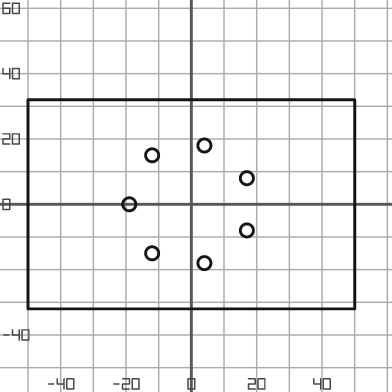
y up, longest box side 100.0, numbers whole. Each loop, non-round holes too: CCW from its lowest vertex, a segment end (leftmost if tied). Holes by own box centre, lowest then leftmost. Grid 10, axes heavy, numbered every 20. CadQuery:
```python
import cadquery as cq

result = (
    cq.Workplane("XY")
    .moveTo(-50.0, -32.0)
    .lineTo(50.0, -32.0)
    .lineTo(50.0, 32.0)
    .lineTo(-50.0, 32.0)
    .close()
    .moveTo(4.0, -18.0)
    .circle(2.0)
    .moveTo(-12.0, -15.0)
    .circle(2.0)
    .moveTo(17.0, -8.0)
    .circle(2.0)
    .moveTo(-19.0, 0.0)
    .circle(2.0)
    .moveTo(17.0, 8.0)
    .circle(2.0)
    .moveTo(-12.0, 15.0)
    .circle(2.0)
    .moveTo(4.0, 18.0)
    .circle(2.0)
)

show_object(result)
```